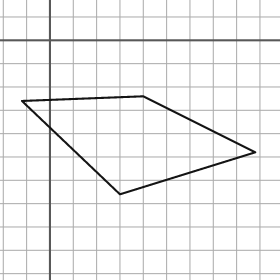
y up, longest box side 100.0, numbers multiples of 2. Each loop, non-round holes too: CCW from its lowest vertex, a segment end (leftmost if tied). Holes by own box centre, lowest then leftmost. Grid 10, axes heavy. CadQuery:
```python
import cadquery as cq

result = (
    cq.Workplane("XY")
    .moveTo(30.0, -66.0)
    .lineTo(88.0, -48.0)
    .lineTo(40.0, -24.0)
    .lineTo(-12.0, -26.0)
    .close()
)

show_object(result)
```